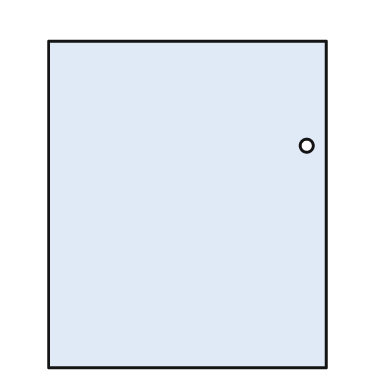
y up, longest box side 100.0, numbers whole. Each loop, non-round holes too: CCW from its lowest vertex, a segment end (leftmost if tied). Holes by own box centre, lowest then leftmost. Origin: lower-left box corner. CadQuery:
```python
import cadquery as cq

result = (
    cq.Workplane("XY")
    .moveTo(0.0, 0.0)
    .lineTo(85.0, 0.0)
    .lineTo(85.0, 100.0)
    .lineTo(0.0, 100.0)
    .close()
    .moveTo(79.0, 68.0)
    .circle(2.0)
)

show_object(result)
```